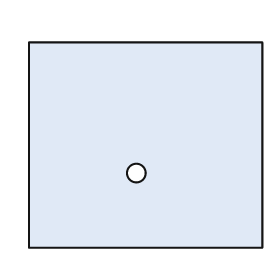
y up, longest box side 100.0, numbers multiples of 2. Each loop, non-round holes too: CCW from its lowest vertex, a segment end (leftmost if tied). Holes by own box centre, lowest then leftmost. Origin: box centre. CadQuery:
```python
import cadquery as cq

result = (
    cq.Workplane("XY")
    .moveTo(-50.0, -44.0)
    .lineTo(50.0, -44.0)
    .lineTo(50.0, 44.0)
    .lineTo(-50.0, 44.0)
    .close()
    .moveTo(-4.0, -12.0)
    .circle(4.0)
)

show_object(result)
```